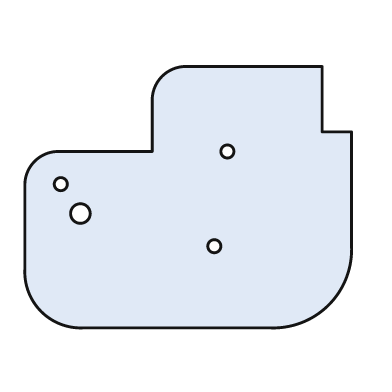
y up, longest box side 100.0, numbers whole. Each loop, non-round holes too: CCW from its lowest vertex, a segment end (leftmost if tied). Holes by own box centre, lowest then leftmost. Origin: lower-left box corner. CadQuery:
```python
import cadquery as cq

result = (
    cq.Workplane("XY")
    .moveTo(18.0, 0.0)
    .lineTo(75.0, 0.0)
    .threePointArc((93.0, 7.0), (100.0, 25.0))
    .lineTo(100.0, 60.0)
    .lineTo(91.0, 60.0)
    .lineTo(91.0, 80.0)
    .lineTo(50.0, 80.0)
    .threePointArc((42.0, 77.0), (39.0, 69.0))
    .lineTo(39.0, 54.0)
    .lineTo(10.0, 54.0)
    .threePointArc((3.0, 51.0), (0.0, 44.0))
    .lineTo(0.0, 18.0)
    .threePointArc((5.0, 5.0), (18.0, 0.0))
    .close()
    .moveTo(58.0, 25.0)
    .circle(2.0)
    .moveTo(17.0, 35.0)
    .circle(3.0)
    .moveTo(11.0, 44.0)
    .circle(2.0)
    .moveTo(62.0, 54.0)
    .circle(2.0)
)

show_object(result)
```